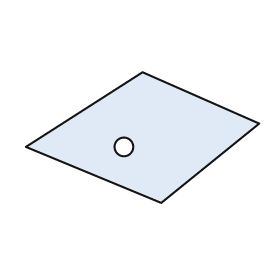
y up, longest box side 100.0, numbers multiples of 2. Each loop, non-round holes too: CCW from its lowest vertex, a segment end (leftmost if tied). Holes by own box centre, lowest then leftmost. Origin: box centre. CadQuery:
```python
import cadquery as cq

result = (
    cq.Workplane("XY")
    .moveTo(8.0, -28.0)
    .lineTo(50.0, 6.0)
    .lineTo(0.0, 28.0)
    .lineTo(-50.0, -4.0)
    .close()
    .moveTo(-8.0, -4.0)
    .circle(4.0)
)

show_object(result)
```